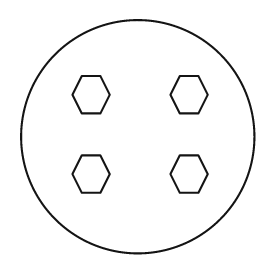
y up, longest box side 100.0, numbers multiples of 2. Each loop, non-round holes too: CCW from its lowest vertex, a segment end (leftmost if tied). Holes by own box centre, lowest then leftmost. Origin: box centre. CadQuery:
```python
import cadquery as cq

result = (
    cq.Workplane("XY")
    .moveTo(0.0, 0.0)
    .circle(50.0)
    .moveTo(-24.0, -24.0)
    .lineTo(-16.0, -24.0)
    .lineTo(-12.0, -16.0)
    .lineTo(-16.0, -8.0)
    .lineTo(-24.0, -8.0)
    .lineTo(-28.0, -16.0)
    .close()
    .moveTo(18.0, -24.0)
    .lineTo(26.0, -24.0)
    .lineTo(30.0, -16.0)
    .lineTo(26.0, -8.0)
    .lineTo(18.0, -8.0)
    .lineTo(14.0, -16.0)
    .close()
    .moveTo(-24.0, 10.0)
    .lineTo(-16.0, 10.0)
    .lineTo(-12.0, 18.0)
    .lineTo(-16.0, 26.0)
    .lineTo(-24.0, 26.0)
    .lineTo(-28.0, 18.0)
    .close()
    .moveTo(18.0, 10.0)
    .lineTo(26.0, 10.0)
    .lineTo(30.0, 18.0)
    .lineTo(26.0, 26.0)
    .lineTo(18.0, 26.0)
    .lineTo(14.0, 18.0)
    .close()
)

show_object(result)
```